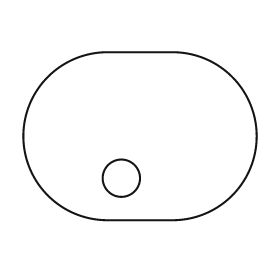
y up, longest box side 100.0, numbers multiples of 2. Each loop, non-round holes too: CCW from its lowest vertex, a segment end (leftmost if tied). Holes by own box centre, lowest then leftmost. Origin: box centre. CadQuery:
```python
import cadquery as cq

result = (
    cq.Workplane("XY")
    .moveTo(-14.0, -36.0)
    .lineTo(14.0, -36.0)
    .threePointArc((50.0, 0.0), (14.0, 36.0))
    .lineTo(-14.0, 36.0)
    .threePointArc((-50.0, 0.0), (-14.0, -36.0))
    .close()
    .moveTo(-8.0, -18.0)
    .circle(8.0)
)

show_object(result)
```